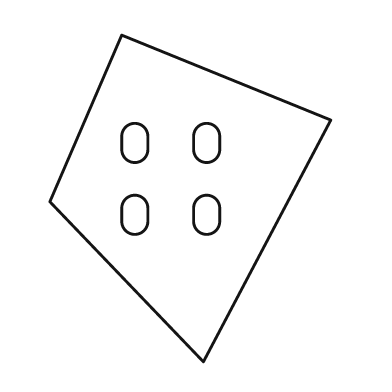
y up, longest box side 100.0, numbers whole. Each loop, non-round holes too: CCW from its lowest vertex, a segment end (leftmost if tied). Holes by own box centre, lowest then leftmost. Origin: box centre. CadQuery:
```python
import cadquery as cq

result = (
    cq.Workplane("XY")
    .moveTo(4.0, -50.0)
    .lineTo(43.0, 24.0)
    .lineTo(-21.0, 50.0)
    .lineTo(-43.0, -1.0)
    .close()
    .moveTo(-21.0, -7.0)
    .threePointArc((-17.0, -11.0), (-13.0, -7.0))
    .lineTo(-13.0, -3.0)
    .threePointArc((-17.0, 1.0), (-21.0, -3.0))
    .close()
    .moveTo(1.0, -7.0)
    .threePointArc((5.0, -11.0), (9.0, -7.0))
    .lineTo(9.0, -3.0)
    .threePointArc((5.0, 1.0), (1.0, -3.0))
    .close()
    .moveTo(-21.0, 15.0)
    .threePointArc((-17.0, 11.0), (-13.0, 15.0))
    .lineTo(-13.0, 19.0)
    .threePointArc((-17.0, 23.0), (-21.0, 19.0))
    .close()
    .moveTo(1.0, 15.0)
    .threePointArc((5.0, 11.0), (9.0, 15.0))
    .lineTo(9.0, 19.0)
    .threePointArc((5.0, 23.0), (1.0, 19.0))
    .close()
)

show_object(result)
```